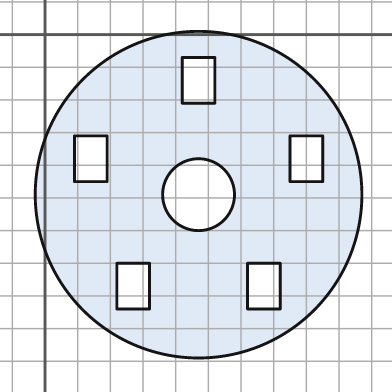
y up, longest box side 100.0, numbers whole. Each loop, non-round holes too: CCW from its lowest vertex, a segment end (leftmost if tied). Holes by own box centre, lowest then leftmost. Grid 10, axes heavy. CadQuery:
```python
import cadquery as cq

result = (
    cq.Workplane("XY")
    .moveTo(47.0, -49.0)
    .circle(50.0)
    .moveTo(22.0, -84.0)
    .lineTo(32.0, -84.0)
    .lineTo(32.0, -70.0)
    .lineTo(22.0, -70.0)
    .close()
    .moveTo(62.0, -84.0)
    .lineTo(72.0, -84.0)
    .lineTo(72.0, -70.0)
    .lineTo(62.0, -70.0)
    .close()
    .moveTo(47.0, -49.0)
    .circle(11.0)
    .moveTo(9.0, -45.0)
    .lineTo(19.0, -45.0)
    .lineTo(19.0, -31.0)
    .lineTo(9.0, -31.0)
    .close()
    .moveTo(75.0, -45.0)
    .lineTo(85.0, -45.0)
    .lineTo(85.0, -31.0)
    .lineTo(75.0, -31.0)
    .close()
    .moveTo(42.0, -21.0)
    .lineTo(52.0, -21.0)
    .lineTo(52.0, -7.0)
    .lineTo(42.0, -7.0)
    .close()
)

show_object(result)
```